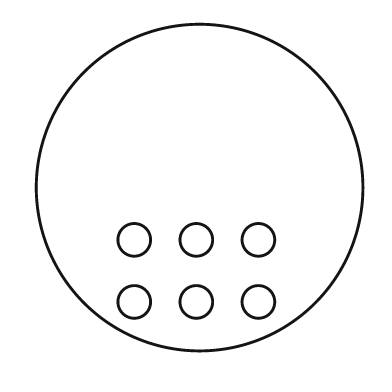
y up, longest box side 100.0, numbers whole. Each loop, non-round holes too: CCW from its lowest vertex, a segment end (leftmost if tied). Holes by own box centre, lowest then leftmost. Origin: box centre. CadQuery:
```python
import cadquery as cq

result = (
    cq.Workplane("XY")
    .moveTo(0.0, 0.0)
    .circle(50.0)
    .moveTo(-20.0, -35.0)
    .circle(5.0)
    .moveTo(-1.0, -35.0)
    .circle(5.0)
    .moveTo(18.0, -35.0)
    .circle(5.0)
    .moveTo(-20.0, -16.0)
    .circle(5.0)
    .moveTo(-1.0, -16.0)
    .circle(5.0)
    .moveTo(18.0, -16.0)
    .circle(5.0)
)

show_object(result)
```